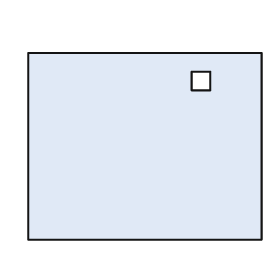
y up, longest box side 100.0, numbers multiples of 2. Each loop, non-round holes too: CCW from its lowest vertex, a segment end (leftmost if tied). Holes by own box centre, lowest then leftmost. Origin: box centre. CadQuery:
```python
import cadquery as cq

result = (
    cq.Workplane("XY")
    .moveTo(-50.0, -40.0)
    .lineTo(50.0, -40.0)
    .lineTo(50.0, 40.0)
    .lineTo(-50.0, 40.0)
    .close()
    .moveTo(20.0, 24.0)
    .lineTo(28.0, 24.0)
    .lineTo(28.0, 32.0)
    .lineTo(20.0, 32.0)
    .close()
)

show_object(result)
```